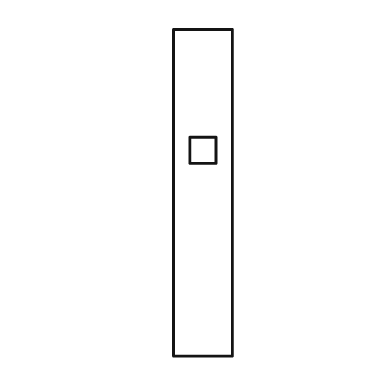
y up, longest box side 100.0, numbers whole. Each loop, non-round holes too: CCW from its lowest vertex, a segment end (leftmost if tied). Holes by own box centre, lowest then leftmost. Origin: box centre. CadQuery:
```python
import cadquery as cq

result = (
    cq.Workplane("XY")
    .moveTo(-9.0, -50.0)
    .lineTo(9.0, -50.0)
    .lineTo(9.0, 50.0)
    .lineTo(-9.0, 50.0)
    .close()
    .moveTo(-4.0, 9.0)
    .lineTo(4.0, 9.0)
    .lineTo(4.0, 17.0)
    .lineTo(-4.0, 17.0)
    .close()
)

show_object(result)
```